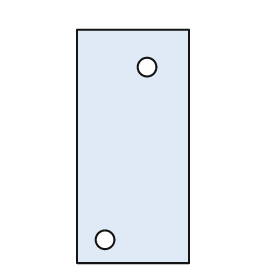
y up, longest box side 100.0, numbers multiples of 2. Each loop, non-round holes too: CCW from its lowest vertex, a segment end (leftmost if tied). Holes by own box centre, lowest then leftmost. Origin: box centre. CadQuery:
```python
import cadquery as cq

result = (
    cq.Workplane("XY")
    .moveTo(-24.0, -50.0)
    .lineTo(24.0, -50.0)
    .lineTo(24.0, 50.0)
    .lineTo(-24.0, 50.0)
    .close()
    .moveTo(-12.0, -40.0)
    .circle(4.0)
    .moveTo(6.0, 34.0)
    .circle(4.0)
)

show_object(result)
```